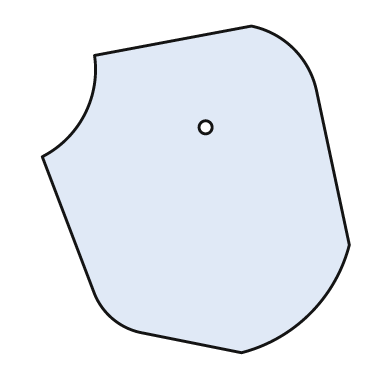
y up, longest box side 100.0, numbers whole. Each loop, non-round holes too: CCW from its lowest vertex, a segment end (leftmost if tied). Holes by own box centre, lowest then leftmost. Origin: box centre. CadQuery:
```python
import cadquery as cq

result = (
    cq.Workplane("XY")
    .moveTo(14.0, -50.0)
    .threePointArc((35.0, -38.0), (47.0, -17.0))
    .lineTo(37.0, 30.0)
    .threePointArc((30.0, 43.0), (17.0, 50.0))
    .lineTo(-31.0, 41.0)
    .threePointArc((-34.0, 23.0), (-47.0, 10.0))
    .lineTo(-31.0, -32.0)
    .threePointArc((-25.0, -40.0), (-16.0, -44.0))
    .close()
    .moveTo(3.0, 19.0)
    .circle(2.0)
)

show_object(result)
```